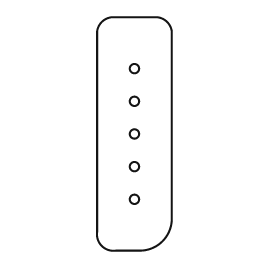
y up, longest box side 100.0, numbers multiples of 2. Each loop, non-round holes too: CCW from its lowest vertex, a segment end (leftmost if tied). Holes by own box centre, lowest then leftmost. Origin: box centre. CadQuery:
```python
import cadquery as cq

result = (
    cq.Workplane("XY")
    .moveTo(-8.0, -50.0)
    .lineTo(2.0, -50.0)
    .threePointArc((12.0, -46.0), (16.0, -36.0))
    .lineTo(16.0, 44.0)
    .threePointArc((14.0, 48.0), (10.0, 50.0))
    .lineTo(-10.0, 50.0)
    .threePointArc((-14.0, 48.0), (-16.0, 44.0))
    .lineTo(-16.0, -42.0)
    .threePointArc((-14.0, -48.0), (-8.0, -50.0))
    .close()
    .moveTo(0.0, -28.0)
    .circle(2.0)
    .moveTo(0.0, -14.0)
    .circle(2.0)
    .moveTo(0.0, 0.0)
    .circle(2.0)
    .moveTo(0.0, 14.0)
    .circle(2.0)
    .moveTo(0.0, 28.0)
    .circle(2.0)
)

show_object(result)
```